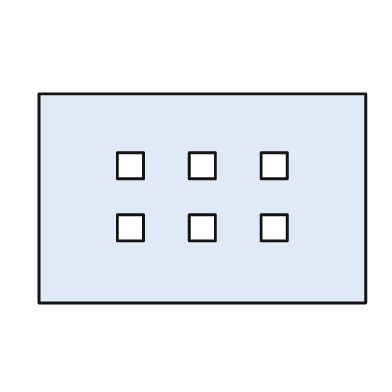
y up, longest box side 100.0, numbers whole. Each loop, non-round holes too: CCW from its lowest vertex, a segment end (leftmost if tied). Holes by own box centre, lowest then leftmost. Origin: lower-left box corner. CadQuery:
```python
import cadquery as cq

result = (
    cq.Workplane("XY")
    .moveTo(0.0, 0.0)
    .lineTo(100.0, 0.0)
    .lineTo(100.0, 64.0)
    .lineTo(0.0, 64.0)
    .close()
    .moveTo(24.0, 19.0)
    .lineTo(32.0, 19.0)
    .lineTo(32.0, 27.0)
    .lineTo(24.0, 27.0)
    .close()
    .moveTo(46.0, 19.0)
    .lineTo(54.0, 19.0)
    .lineTo(54.0, 27.0)
    .lineTo(46.0, 27.0)
    .close()
    .moveTo(68.0, 19.0)
    .lineTo(76.0, 19.0)
    .lineTo(76.0, 27.0)
    .lineTo(68.0, 27.0)
    .close()
    .moveTo(24.0, 38.0)
    .lineTo(32.0, 38.0)
    .lineTo(32.0, 46.0)
    .lineTo(24.0, 46.0)
    .close()
    .moveTo(46.0, 38.0)
    .lineTo(54.0, 38.0)
    .lineTo(54.0, 46.0)
    .lineTo(46.0, 46.0)
    .close()
    .moveTo(68.0, 38.0)
    .lineTo(76.0, 38.0)
    .lineTo(76.0, 46.0)
    .lineTo(68.0, 46.0)
    .close()
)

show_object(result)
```